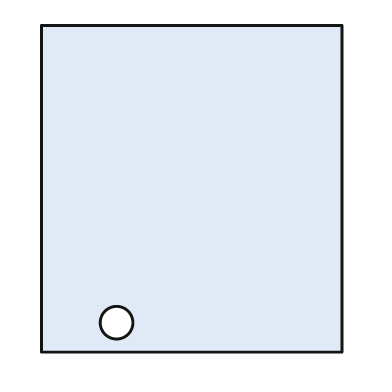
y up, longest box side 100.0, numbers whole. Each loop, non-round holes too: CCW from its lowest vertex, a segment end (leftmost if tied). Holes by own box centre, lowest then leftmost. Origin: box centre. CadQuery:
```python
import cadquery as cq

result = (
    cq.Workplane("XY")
    .moveTo(-46.0, -50.0)
    .lineTo(46.0, -50.0)
    .lineTo(46.0, 50.0)
    .lineTo(-46.0, 50.0)
    .close()
    .moveTo(-23.0, -41.0)
    .circle(5.0)
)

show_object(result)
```